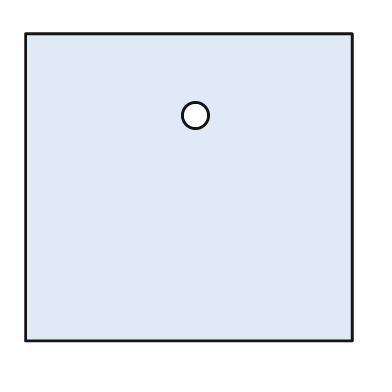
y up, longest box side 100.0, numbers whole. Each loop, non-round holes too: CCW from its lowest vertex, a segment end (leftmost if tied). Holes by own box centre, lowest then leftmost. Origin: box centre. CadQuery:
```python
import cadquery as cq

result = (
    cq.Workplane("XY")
    .moveTo(-50.0, -47.0)
    .lineTo(50.0, -47.0)
    .lineTo(50.0, 47.0)
    .lineTo(-50.0, 47.0)
    .close()
    .moveTo(2.0, 22.0)
    .circle(4.0)
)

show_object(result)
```